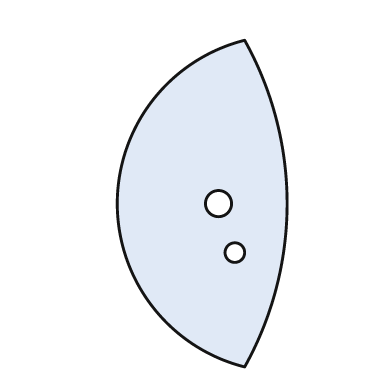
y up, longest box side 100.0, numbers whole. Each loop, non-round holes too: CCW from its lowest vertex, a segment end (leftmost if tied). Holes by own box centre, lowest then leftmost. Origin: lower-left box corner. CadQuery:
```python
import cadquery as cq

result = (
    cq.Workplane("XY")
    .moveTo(39.0, 0.0)
    .threePointArc((52.0, 50.0), (39.0, 100.0))
    .threePointArc((0.0, 50.0), (39.0, 0.0))
    .close()
    .moveTo(36.0, 35.0)
    .circle(3.0)
    .moveTo(31.0, 50.0)
    .circle(4.0)
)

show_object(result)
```